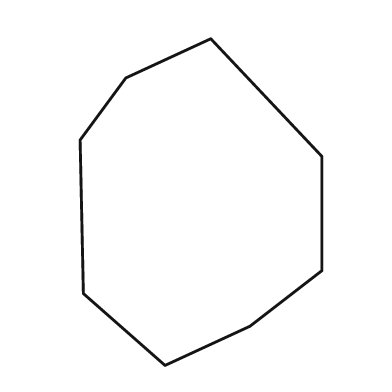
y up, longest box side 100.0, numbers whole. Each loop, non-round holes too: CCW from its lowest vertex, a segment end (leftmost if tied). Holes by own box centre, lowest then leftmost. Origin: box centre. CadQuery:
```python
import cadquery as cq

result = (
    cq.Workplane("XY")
    .moveTo(-11.0, -50.0)
    .lineTo(15.0, -38.0)
    .lineTo(37.0, -21.0)
    .lineTo(37.0, 14.0)
    .lineTo(3.0, 50.0)
    .lineTo(-23.0, 38.0)
    .lineTo(-37.0, 19.0)
    .lineTo(-36.0, -28.0)
    .close()
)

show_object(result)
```